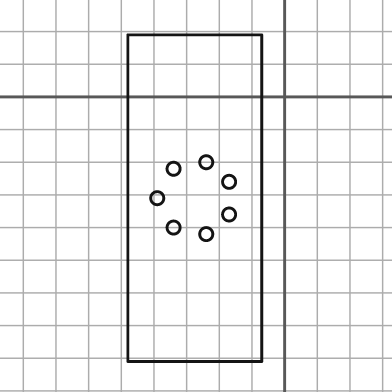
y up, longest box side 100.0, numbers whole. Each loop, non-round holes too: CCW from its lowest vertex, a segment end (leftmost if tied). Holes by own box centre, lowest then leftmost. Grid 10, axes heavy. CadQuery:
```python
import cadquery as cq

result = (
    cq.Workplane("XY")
    .moveTo(-48.0, -81.0)
    .lineTo(-7.0, -81.0)
    .lineTo(-7.0, 19.0)
    .lineTo(-48.0, 19.0)
    .close()
    .moveTo(-24.0, -42.0)
    .circle(2.0)
    .moveTo(-34.0, -40.0)
    .circle(2.0)
    .moveTo(-17.0, -36.0)
    .circle(2.0)
    .moveTo(-39.0, -31.0)
    .circle(2.0)
    .moveTo(-17.0, -26.0)
    .circle(2.0)
    .moveTo(-34.0, -22.0)
    .circle(2.0)
    .moveTo(-24.0, -20.0)
    .circle(2.0)
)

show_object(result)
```